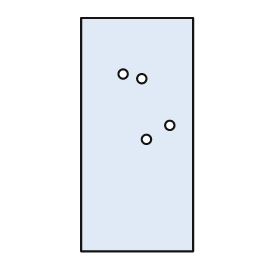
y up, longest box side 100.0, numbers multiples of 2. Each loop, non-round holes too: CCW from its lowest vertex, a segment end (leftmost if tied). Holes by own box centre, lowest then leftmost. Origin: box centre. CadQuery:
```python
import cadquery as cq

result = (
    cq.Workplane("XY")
    .moveTo(-24.0, -50.0)
    .lineTo(24.0, -50.0)
    .lineTo(24.0, 50.0)
    .lineTo(-24.0, 50.0)
    .close()
    .moveTo(4.0, -2.0)
    .circle(2.0)
    .moveTo(14.0, 4.0)
    .circle(2.0)
    .moveTo(2.0, 24.0)
    .circle(2.0)
    .moveTo(-6.0, 26.0)
    .circle(2.0)
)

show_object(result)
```